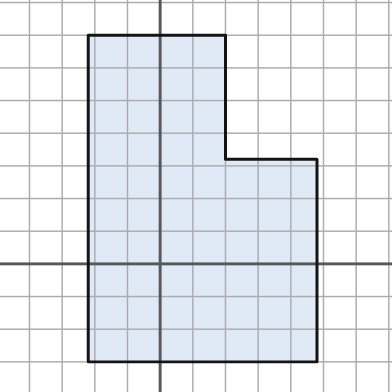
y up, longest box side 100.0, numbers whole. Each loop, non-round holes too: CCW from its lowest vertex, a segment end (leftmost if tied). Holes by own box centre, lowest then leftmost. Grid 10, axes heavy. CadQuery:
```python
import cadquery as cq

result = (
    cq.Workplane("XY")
    .moveTo(-22.0, -30.0)
    .lineTo(48.0, -30.0)
    .lineTo(48.0, 32.0)
    .lineTo(20.0, 32.0)
    .lineTo(20.0, 70.0)
    .lineTo(-22.0, 70.0)
    .close()
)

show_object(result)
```